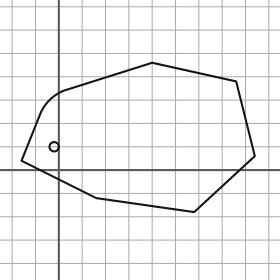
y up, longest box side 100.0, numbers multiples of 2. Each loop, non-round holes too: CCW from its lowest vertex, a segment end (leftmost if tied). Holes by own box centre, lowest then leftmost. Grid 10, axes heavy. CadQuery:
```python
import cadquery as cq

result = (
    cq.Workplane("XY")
    .moveTo(58.0, -18.0)
    .lineTo(84.0, 6.0)
    .lineTo(76.0, 38.0)
    .lineTo(40.0, 46.0)
    .lineTo(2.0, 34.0)
    .threePointArc((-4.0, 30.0), (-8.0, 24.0))
    .lineTo(-16.0, 4.0)
    .lineTo(16.0, -12.0)
    .close()
    .moveTo(-2.0, 10.0)
    .circle(2.0)
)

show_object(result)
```